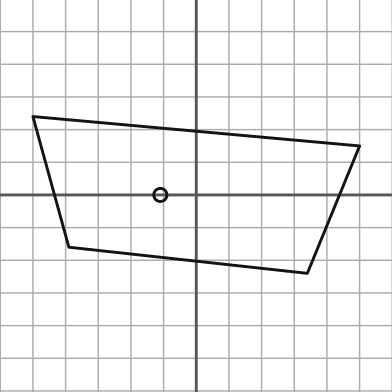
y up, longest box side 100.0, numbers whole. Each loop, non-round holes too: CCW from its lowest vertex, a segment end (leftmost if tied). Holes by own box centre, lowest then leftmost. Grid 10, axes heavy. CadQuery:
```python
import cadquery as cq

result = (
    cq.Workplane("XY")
    .moveTo(34.0, -24.0)
    .lineTo(50.0, 15.0)
    .lineTo(-50.0, 24.0)
    .lineTo(-39.0, -16.0)
    .close()
    .moveTo(-11.0, 0.0)
    .circle(2.0)
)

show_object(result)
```